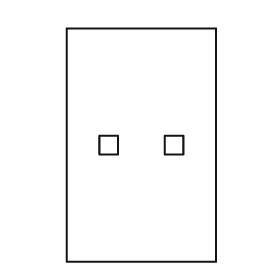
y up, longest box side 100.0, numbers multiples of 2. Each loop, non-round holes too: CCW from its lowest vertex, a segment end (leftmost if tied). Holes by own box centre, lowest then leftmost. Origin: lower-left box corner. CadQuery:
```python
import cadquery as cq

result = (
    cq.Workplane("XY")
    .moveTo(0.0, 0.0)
    .lineTo(64.0, 0.0)
    .lineTo(64.0, 100.0)
    .lineTo(0.0, 100.0)
    .close()
    .moveTo(14.0, 46.0)
    .lineTo(22.0, 46.0)
    .lineTo(22.0, 54.0)
    .lineTo(14.0, 54.0)
    .close()
    .moveTo(42.0, 46.0)
    .lineTo(50.0, 46.0)
    .lineTo(50.0, 54.0)
    .lineTo(42.0, 54.0)
    .close()
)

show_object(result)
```